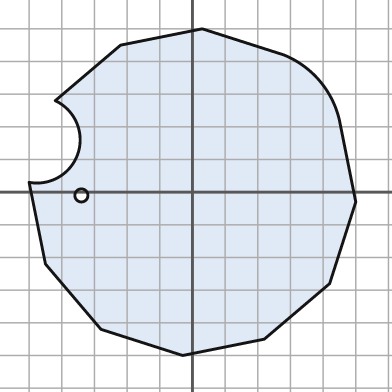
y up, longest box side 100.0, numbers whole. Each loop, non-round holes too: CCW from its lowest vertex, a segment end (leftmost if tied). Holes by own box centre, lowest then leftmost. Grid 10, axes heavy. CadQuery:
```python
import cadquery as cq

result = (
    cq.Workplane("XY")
    .moveTo(-3.0, -50.0)
    .lineTo(22.0, -45.0)
    .lineTo(42.0, -28.0)
    .lineTo(50.0, -3.0)
    .lineTo(45.0, 22.0)
    .threePointArc((39.0, 34.0), (28.0, 42.0))
    .lineTo(3.0, 50.0)
    .lineTo(-22.0, 45.0)
    .lineTo(-42.0, 28.0)
    .threePointArc((-35.0, 12.0), (-50.0, 3.0))
    .lineTo(-45.0, -22.0)
    .lineTo(-28.0, -42.0)
    .close()
    .moveTo(-34.0, -1.0)
    .circle(2.0)
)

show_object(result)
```